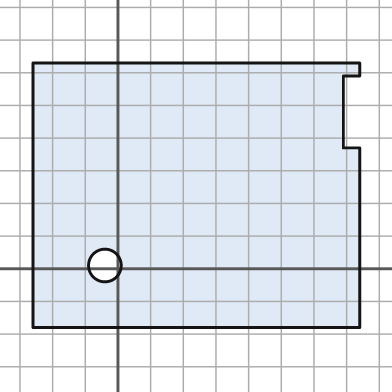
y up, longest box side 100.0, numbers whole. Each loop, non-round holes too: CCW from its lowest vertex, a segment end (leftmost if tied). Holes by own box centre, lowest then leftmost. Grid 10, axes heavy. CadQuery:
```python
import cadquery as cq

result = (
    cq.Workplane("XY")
    .moveTo(-26.0, -18.0)
    .lineTo(74.0, -18.0)
    .lineTo(74.0, 37.0)
    .lineTo(69.0, 37.0)
    .lineTo(69.0, 59.0)
    .lineTo(74.0, 59.0)
    .lineTo(74.0, 63.0)
    .lineTo(-26.0, 63.0)
    .close()
    .moveTo(-4.0, 1.0)
    .circle(5.0)
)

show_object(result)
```